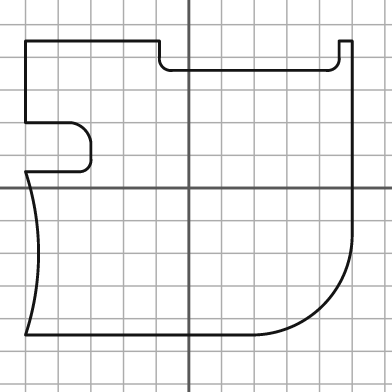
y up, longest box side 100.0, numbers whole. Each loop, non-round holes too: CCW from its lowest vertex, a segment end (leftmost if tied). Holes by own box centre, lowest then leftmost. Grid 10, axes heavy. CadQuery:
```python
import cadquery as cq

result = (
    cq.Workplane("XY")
    .moveTo(-50.0, -45.0)
    .lineTo(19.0, -45.0)
    .threePointArc((41.0, -36.0), (50.0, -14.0))
    .lineTo(50.0, 45.0)
    .lineTo(46.0, 45.0)
    .lineTo(46.0, 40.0)
    .threePointArc((45.0, 37.0), (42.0, 36.0))
    .lineTo(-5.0, 36.0)
    .threePointArc((-8.0, 37.0), (-9.0, 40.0))
    .lineTo(-9.0, 45.0)
    .lineTo(-50.0, 45.0)
    .lineTo(-50.0, 20.0)
    .lineTo(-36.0, 20.0)
    .threePointArc((-32.0, 18.0), (-30.0, 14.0))
    .lineTo(-30.0, 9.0)
    .threePointArc((-31.0, 6.0), (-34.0, 5.0))
    .lineTo(-50.0, 5.0)
    .threePointArc((-46.0, -20.0), (-50.0, -45.0))
    .close()
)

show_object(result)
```